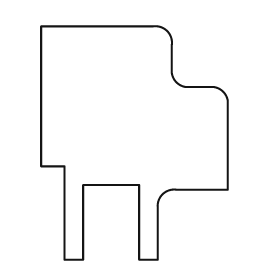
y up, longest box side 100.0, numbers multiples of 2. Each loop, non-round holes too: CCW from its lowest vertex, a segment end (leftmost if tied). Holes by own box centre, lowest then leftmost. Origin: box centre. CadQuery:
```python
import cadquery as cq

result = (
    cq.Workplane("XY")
    .moveTo(-30.0, -50.0)
    .lineTo(-22.0, -50.0)
    .lineTo(-22.0, -18.0)
    .lineTo(2.0, -18.0)
    .lineTo(2.0, -50.0)
    .lineTo(10.0, -50.0)
    .lineTo(10.0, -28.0)
    .threePointArc((12.0, -22.0), (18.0, -20.0))
    .lineTo(40.0, -20.0)
    .lineTo(40.0, 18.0)
    .threePointArc((38.0, 22.0), (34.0, 24.0))
    .lineTo(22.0, 24.0)
    .threePointArc((18.0, 26.0), (16.0, 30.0))
    .lineTo(16.0, 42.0)
    .threePointArc((14.0, 48.0), (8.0, 50.0))
    .lineTo(-40.0, 50.0)
    .lineTo(-40.0, -10.0)
    .lineTo(-30.0, -10.0)
    .close()
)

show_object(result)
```